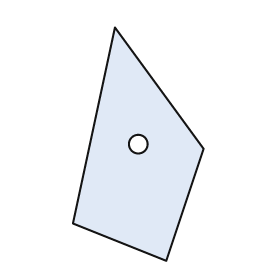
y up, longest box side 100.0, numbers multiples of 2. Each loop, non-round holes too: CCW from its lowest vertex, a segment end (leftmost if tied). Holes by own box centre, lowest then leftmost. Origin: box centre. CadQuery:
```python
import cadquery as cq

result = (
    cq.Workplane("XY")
    .moveTo(12.0, -50.0)
    .lineTo(28.0, -2.0)
    .lineTo(-10.0, 50.0)
    .lineTo(-28.0, -34.0)
    .close()
    .moveTo(0.0, 0.0)
    .circle(4.0)
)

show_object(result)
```